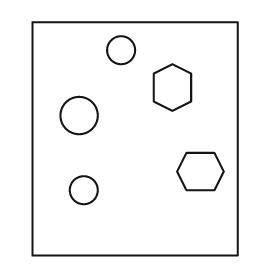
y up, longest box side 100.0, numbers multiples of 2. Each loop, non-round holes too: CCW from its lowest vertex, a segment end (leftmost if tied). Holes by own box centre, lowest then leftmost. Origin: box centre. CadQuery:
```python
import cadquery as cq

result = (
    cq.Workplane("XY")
    .moveTo(-44.0, -50.0)
    .lineTo(44.0, -50.0)
    .lineTo(44.0, 50.0)
    .lineTo(-44.0, 50.0)
    .close()
    .moveTo(-22.0, -22.0)
    .circle(6.0)
    .moveTo(22.0, -22.0)
    .lineTo(34.0, -22.0)
    .lineTo(38.0, -14.0)
    .lineTo(34.0, -6.0)
    .lineTo(22.0, -6.0)
    .lineTo(18.0, -14.0)
    .close()
    .moveTo(-24.0, 10.0)
    .circle(8.0)
    .moveTo(16.0, 12.0)
    .lineTo(24.0, 16.0)
    .lineTo(24.0, 28.0)
    .lineTo(16.0, 32.0)
    .lineTo(8.0, 28.0)
    .lineTo(8.0, 16.0)
    .close()
    .moveTo(-6.0, 38.0)
    .circle(6.0)
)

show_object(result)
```